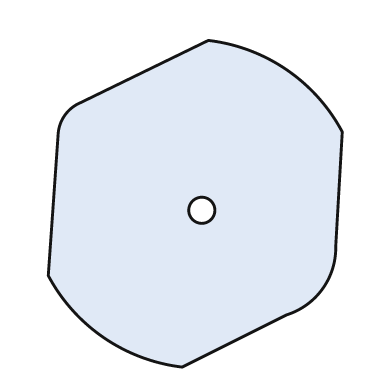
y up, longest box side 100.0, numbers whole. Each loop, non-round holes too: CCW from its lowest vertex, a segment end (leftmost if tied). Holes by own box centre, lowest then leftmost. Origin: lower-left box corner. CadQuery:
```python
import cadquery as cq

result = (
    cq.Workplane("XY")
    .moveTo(41.0, 0.0)
    .lineTo(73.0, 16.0)
    .threePointArc((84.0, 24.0), (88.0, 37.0))
    .lineTo(90.0, 72.0)
    .threePointArc((73.0, 91.0), (49.0, 100.0))
    .lineTo(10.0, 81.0)
    .threePointArc((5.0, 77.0), (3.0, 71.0))
    .lineTo(0.0, 28.0)
    .threePointArc((17.0, 9.0), (41.0, 0.0))
    .close()
    .moveTo(47.0, 48.0)
    .circle(4.0)
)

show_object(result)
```